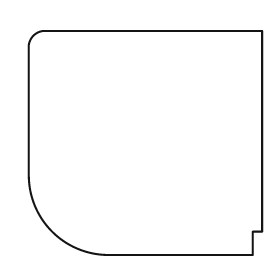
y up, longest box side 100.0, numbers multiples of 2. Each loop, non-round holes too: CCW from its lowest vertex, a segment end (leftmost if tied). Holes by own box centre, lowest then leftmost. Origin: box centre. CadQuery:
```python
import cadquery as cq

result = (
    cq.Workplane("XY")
    .moveTo(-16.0, -48.0)
    .lineTo(46.0, -48.0)
    .lineTo(46.0, -38.0)
    .lineTo(50.0, -38.0)
    .lineTo(50.0, 48.0)
    .lineTo(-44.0, 48.0)
    .threePointArc((-48.0, 46.0), (-50.0, 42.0))
    .lineTo(-50.0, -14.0)
    .threePointArc((-40.0, -38.0), (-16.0, -48.0))
    .close()
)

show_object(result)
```